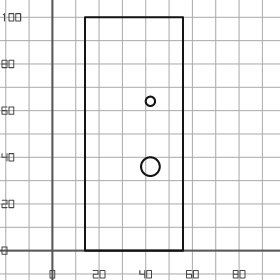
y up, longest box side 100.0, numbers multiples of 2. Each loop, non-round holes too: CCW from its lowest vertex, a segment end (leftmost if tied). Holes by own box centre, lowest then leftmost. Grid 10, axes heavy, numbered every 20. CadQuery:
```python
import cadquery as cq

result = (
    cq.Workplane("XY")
    .moveTo(14.0, 0.0)
    .lineTo(56.0, 0.0)
    .lineTo(56.0, 100.0)
    .lineTo(14.0, 100.0)
    .close()
    .moveTo(42.0, 36.0)
    .circle(4.0)
    .moveTo(42.0, 64.0)
    .circle(2.0)
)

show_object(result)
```